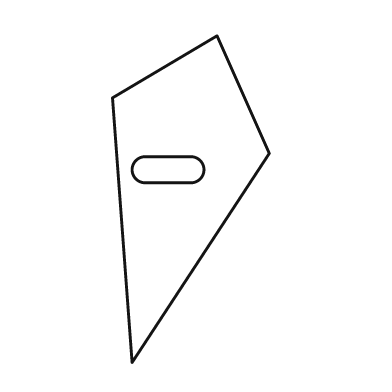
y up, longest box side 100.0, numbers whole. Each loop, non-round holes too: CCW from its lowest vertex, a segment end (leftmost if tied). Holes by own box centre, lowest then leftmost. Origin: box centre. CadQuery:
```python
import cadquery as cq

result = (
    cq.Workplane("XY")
    .moveTo(-18.0, -50.0)
    .lineTo(24.0, 14.0)
    .lineTo(8.0, 50.0)
    .lineTo(-24.0, 31.0)
    .close()
    .moveTo(-14.0, 5.0)
    .lineTo(0.0, 5.0)
    .threePointArc((4.0, 9.0), (0.0, 13.0))
    .lineTo(-14.0, 13.0)
    .threePointArc((-18.0, 9.0), (-14.0, 5.0))
    .close()
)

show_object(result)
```